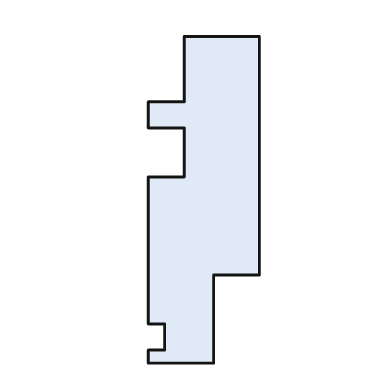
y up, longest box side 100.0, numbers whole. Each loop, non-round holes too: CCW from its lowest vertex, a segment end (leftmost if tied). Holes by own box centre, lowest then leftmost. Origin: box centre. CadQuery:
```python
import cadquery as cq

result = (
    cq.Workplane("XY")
    .moveTo(-17.0, -50.0)
    .lineTo(3.0, -50.0)
    .lineTo(3.0, -23.0)
    .lineTo(17.0, -23.0)
    .lineTo(17.0, 50.0)
    .lineTo(-6.0, 50.0)
    .lineTo(-6.0, 30.0)
    .lineTo(-17.0, 30.0)
    .lineTo(-17.0, 22.0)
    .lineTo(-6.0, 22.0)
    .lineTo(-6.0, 7.0)
    .lineTo(-17.0, 7.0)
    .lineTo(-17.0, -38.0)
    .lineTo(-12.0, -38.0)
    .lineTo(-12.0, -46.0)
    .lineTo(-17.0, -46.0)
    .close()
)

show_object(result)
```